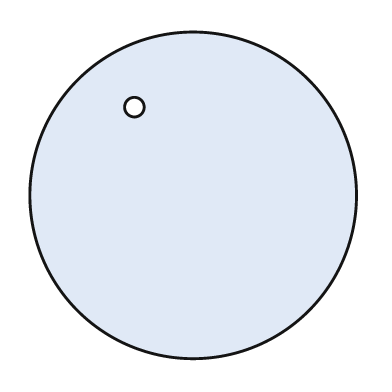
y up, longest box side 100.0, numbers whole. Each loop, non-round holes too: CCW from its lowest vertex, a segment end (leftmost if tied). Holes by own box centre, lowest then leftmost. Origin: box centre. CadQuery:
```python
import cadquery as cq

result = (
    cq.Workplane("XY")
    .moveTo(0.0, 0.0)
    .circle(50.0)
    .moveTo(-18.0, 27.0)
    .circle(3.0)
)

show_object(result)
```